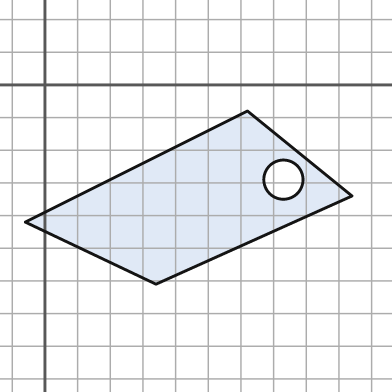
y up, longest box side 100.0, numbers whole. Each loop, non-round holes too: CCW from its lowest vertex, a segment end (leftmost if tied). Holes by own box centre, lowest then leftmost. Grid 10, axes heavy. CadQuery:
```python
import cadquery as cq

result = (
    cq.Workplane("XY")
    .moveTo(34.0, -61.0)
    .lineTo(94.0, -34.0)
    .lineTo(62.0, -8.0)
    .lineTo(-6.0, -42.0)
    .close()
    .moveTo(73.0, -29.0)
    .circle(6.0)
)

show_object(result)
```